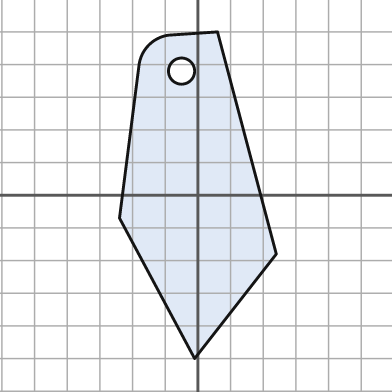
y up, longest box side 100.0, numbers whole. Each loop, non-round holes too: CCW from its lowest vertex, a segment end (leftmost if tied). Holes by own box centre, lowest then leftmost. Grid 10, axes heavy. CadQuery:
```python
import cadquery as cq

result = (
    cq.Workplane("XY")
    .moveTo(-1.0, -50.0)
    .lineTo(24.0, -18.0)
    .lineTo(6.0, 50.0)
    .lineTo(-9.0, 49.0)
    .threePointArc((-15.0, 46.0), (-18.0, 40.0))
    .lineTo(-24.0, -7.0)
    .close()
    .moveTo(-5.0, 38.0)
    .circle(4.0)
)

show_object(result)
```